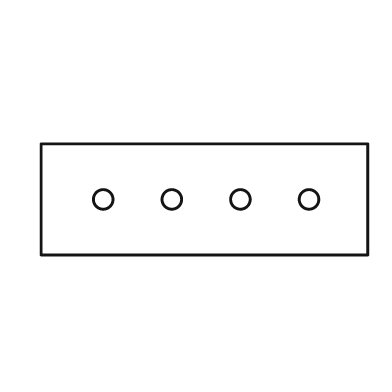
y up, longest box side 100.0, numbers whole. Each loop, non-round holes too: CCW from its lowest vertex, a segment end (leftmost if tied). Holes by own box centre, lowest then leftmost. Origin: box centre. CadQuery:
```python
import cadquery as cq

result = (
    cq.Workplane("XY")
    .moveTo(-50.0, -17.0)
    .lineTo(50.0, -17.0)
    .lineTo(50.0, 17.0)
    .lineTo(-50.0, 17.0)
    .close()
    .moveTo(-31.0, 0.0)
    .circle(3.0)
    .moveTo(-10.0, 0.0)
    .circle(3.0)
    .moveTo(11.0, 0.0)
    .circle(3.0)
    .moveTo(32.0, 0.0)
    .circle(3.0)
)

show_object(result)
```